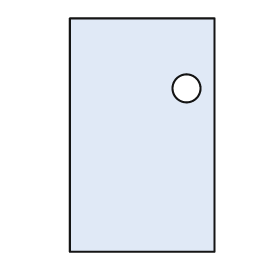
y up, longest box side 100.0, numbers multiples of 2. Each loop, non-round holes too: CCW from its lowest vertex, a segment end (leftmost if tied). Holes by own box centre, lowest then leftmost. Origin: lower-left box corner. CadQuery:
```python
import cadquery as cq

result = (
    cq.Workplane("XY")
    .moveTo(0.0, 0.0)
    .lineTo(62.0, 0.0)
    .lineTo(62.0, 100.0)
    .lineTo(0.0, 100.0)
    .close()
    .moveTo(50.0, 70.0)
    .circle(6.0)
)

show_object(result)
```